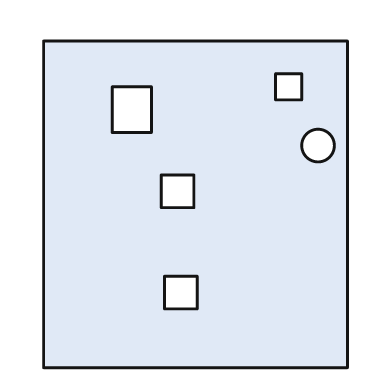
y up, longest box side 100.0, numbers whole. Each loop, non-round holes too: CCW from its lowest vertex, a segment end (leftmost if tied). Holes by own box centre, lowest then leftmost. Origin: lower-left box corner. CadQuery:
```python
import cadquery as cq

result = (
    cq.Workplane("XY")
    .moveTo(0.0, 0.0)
    .lineTo(93.0, 0.0)
    .lineTo(93.0, 100.0)
    .lineTo(0.0, 100.0)
    .close()
    .moveTo(37.0, 18.0)
    .lineTo(47.0, 18.0)
    .lineTo(47.0, 28.0)
    .lineTo(37.0, 28.0)
    .close()
    .moveTo(36.0, 49.0)
    .lineTo(46.0, 49.0)
    .lineTo(46.0, 59.0)
    .lineTo(36.0, 59.0)
    .close()
    .moveTo(84.0, 68.0)
    .circle(5.0)
    .moveTo(21.0, 72.0)
    .lineTo(33.0, 72.0)
    .lineTo(33.0, 86.0)
    .lineTo(21.0, 86.0)
    .close()
    .moveTo(71.0, 82.0)
    .lineTo(79.0, 82.0)
    .lineTo(79.0, 90.0)
    .lineTo(71.0, 90.0)
    .close()
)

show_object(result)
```